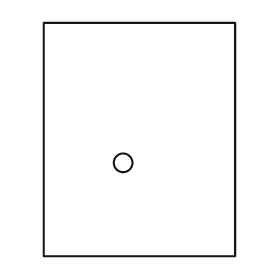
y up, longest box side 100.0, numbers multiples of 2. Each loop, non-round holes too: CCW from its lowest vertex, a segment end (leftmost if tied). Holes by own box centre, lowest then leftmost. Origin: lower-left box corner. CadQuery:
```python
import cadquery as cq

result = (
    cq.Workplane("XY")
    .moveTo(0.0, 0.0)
    .lineTo(82.0, 0.0)
    .lineTo(82.0, 100.0)
    .lineTo(0.0, 100.0)
    .close()
    .moveTo(34.0, 40.0)
    .circle(4.0)
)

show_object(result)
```